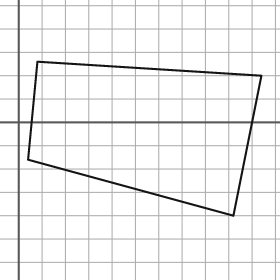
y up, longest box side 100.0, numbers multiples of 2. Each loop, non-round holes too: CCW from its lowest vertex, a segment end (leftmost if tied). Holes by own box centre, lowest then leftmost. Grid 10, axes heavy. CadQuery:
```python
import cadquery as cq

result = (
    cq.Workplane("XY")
    .moveTo(92.0, -40.0)
    .lineTo(104.0, 20.0)
    .lineTo(8.0, 26.0)
    .lineTo(4.0, -16.0)
    .close()
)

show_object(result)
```